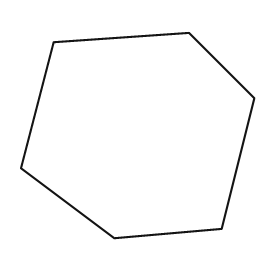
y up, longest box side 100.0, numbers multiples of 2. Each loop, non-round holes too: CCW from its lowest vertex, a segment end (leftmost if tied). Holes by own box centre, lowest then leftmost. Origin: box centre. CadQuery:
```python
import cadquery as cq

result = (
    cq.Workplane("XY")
    .moveTo(-10.0, -44.0)
    .lineTo(36.0, -40.0)
    .lineTo(50.0, 16.0)
    .lineTo(22.0, 44.0)
    .lineTo(-36.0, 40.0)
    .lineTo(-50.0, -14.0)
    .close()
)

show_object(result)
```